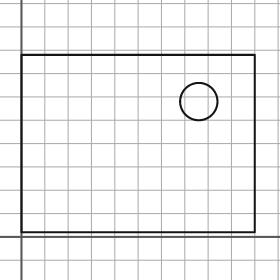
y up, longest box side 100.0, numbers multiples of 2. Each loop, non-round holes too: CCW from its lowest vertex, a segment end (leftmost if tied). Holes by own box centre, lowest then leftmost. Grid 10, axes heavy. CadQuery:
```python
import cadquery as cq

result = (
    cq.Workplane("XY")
    .moveTo(0.0, 2.0)
    .lineTo(100.0, 2.0)
    .lineTo(100.0, 78.0)
    .lineTo(0.0, 78.0)
    .close()
    .moveTo(76.0, 58.0)
    .circle(8.0)
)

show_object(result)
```